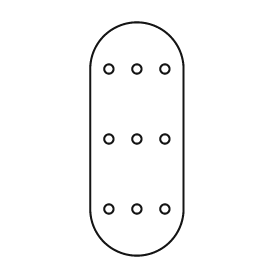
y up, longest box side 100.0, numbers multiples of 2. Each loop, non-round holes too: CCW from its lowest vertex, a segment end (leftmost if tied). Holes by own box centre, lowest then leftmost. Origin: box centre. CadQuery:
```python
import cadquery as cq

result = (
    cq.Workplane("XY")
    .moveTo(-20.0, -30.0)
    .threePointArc((0.0, -50.0), (20.0, -30.0))
    .lineTo(20.0, 30.0)
    .threePointArc((0.0, 50.0), (-20.0, 30.0))
    .close()
    .moveTo(-12.0, -30.0)
    .circle(2.0)
    .moveTo(0.0, -30.0)
    .circle(2.0)
    .moveTo(12.0, -30.0)
    .circle(2.0)
    .moveTo(-12.0, 0.0)
    .circle(2.0)
    .moveTo(0.0, 0.0)
    .circle(2.0)
    .moveTo(12.0, 0.0)
    .circle(2.0)
    .moveTo(-12.0, 30.0)
    .circle(2.0)
    .moveTo(0.0, 30.0)
    .circle(2.0)
    .moveTo(12.0, 30.0)
    .circle(2.0)
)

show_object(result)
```